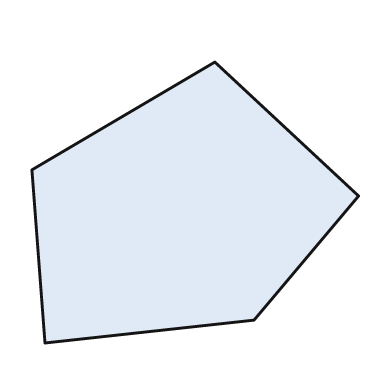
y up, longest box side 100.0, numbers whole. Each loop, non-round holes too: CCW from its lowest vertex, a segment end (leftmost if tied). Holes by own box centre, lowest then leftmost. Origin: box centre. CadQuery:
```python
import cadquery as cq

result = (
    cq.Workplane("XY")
    .moveTo(-46.0, -43.0)
    .lineTo(18.0, -36.0)
    .lineTo(50.0, 2.0)
    .lineTo(6.0, 43.0)
    .lineTo(-50.0, 10.0)
    .close()
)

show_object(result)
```